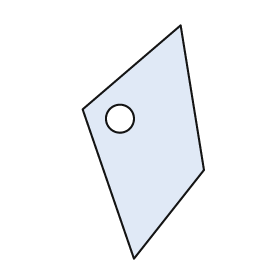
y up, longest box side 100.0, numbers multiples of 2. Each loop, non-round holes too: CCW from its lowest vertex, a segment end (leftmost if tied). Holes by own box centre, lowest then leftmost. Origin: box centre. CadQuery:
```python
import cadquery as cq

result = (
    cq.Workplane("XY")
    .moveTo(-4.0, -50.0)
    .lineTo(26.0, -12.0)
    .lineTo(16.0, 50.0)
    .lineTo(-26.0, 14.0)
    .close()
    .moveTo(-10.0, 10.0)
    .circle(6.0)
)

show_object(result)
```